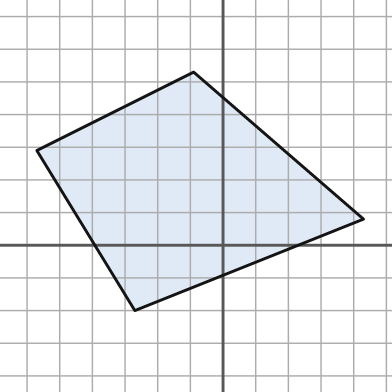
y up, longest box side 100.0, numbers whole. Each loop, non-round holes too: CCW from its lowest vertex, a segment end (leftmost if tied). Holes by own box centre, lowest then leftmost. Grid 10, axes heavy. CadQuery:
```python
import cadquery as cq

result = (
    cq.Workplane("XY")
    .moveTo(-27.0, -20.0)
    .lineTo(43.0, 8.0)
    .lineTo(-9.0, 53.0)
    .lineTo(-57.0, 29.0)
    .close()
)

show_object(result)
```